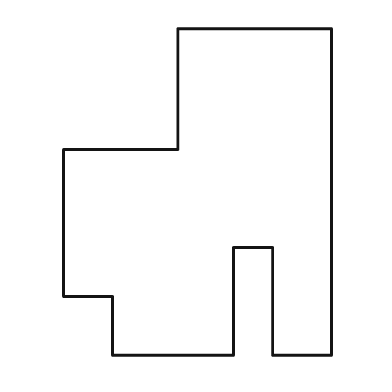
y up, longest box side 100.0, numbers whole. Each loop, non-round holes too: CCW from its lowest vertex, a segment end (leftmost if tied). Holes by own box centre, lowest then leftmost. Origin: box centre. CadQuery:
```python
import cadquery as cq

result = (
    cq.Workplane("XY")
    .moveTo(-26.0, -50.0)
    .lineTo(11.0, -50.0)
    .lineTo(11.0, -17.0)
    .lineTo(23.0, -17.0)
    .lineTo(23.0, -50.0)
    .lineTo(41.0, -50.0)
    .lineTo(41.0, 50.0)
    .lineTo(-6.0, 50.0)
    .lineTo(-6.0, 13.0)
    .lineTo(-41.0, 13.0)
    .lineTo(-41.0, -32.0)
    .lineTo(-26.0, -32.0)
    .close()
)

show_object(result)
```